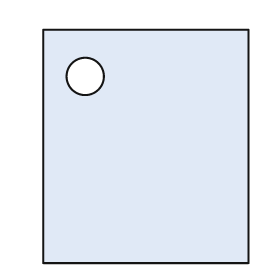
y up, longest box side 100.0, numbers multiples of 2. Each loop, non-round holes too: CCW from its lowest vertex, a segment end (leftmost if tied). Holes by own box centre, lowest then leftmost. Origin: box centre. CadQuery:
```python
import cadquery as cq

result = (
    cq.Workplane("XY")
    .moveTo(-44.0, -50.0)
    .lineTo(44.0, -50.0)
    .lineTo(44.0, 50.0)
    .lineTo(-44.0, 50.0)
    .close()
    .moveTo(-26.0, 30.0)
    .circle(8.0)
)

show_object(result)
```